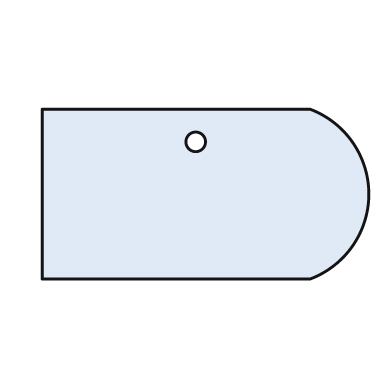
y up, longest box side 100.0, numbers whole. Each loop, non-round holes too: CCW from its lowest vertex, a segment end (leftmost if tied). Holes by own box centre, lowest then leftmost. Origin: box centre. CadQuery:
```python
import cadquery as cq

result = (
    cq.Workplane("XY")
    .moveTo(-50.0, -26.0)
    .lineTo(32.0, -26.0)
    .threePointArc((50.0, 0.0), (32.0, 26.0))
    .lineTo(-50.0, 26.0)
    .close()
    .moveTo(-3.0, 16.0)
    .circle(3.0)
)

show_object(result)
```